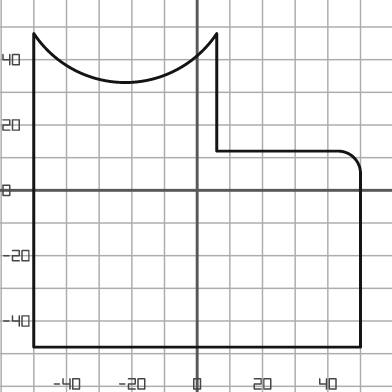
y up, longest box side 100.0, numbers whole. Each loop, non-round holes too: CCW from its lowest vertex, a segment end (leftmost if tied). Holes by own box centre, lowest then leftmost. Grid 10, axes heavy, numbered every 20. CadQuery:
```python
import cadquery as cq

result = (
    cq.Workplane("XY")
    .moveTo(-50.0, -48.0)
    .lineTo(50.0, -48.0)
    .lineTo(50.0, 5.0)
    .threePointArc((48.0, 10.0), (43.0, 12.0))
    .lineTo(6.0, 12.0)
    .lineTo(6.0, 48.0)
    .threePointArc((-22.0, 33.0), (-50.0, 48.0))
    .close()
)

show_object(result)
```